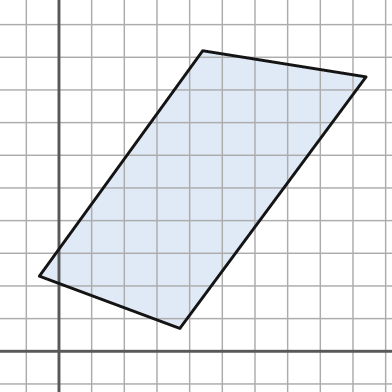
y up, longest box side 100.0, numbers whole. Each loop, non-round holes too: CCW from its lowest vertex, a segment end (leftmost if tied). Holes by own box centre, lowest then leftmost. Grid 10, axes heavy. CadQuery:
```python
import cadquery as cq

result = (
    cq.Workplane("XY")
    .moveTo(37.0, 7.0)
    .lineTo(94.0, 84.0)
    .lineTo(44.0, 92.0)
    .lineTo(-6.0, 23.0)
    .close()
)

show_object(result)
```